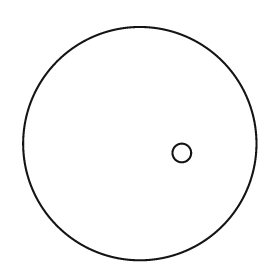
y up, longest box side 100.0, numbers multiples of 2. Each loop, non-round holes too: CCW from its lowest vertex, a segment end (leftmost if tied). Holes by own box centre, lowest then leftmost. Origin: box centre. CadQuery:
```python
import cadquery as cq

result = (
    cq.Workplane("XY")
    .moveTo(0.0, 0.0)
    .circle(50.0)
    .moveTo(18.0, -4.0)
    .circle(4.0)
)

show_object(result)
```